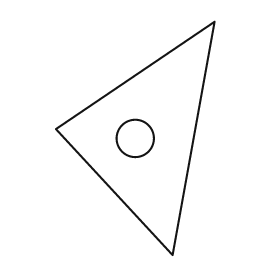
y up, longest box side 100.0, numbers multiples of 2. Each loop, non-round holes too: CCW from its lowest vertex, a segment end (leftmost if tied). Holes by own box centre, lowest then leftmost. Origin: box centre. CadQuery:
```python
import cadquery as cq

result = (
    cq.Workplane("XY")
    .moveTo(16.0, -50.0)
    .lineTo(34.0, 50.0)
    .lineTo(-34.0, 4.0)
    .close()
    .moveTo(0.0, 0.0)
    .circle(8.0)
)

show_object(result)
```